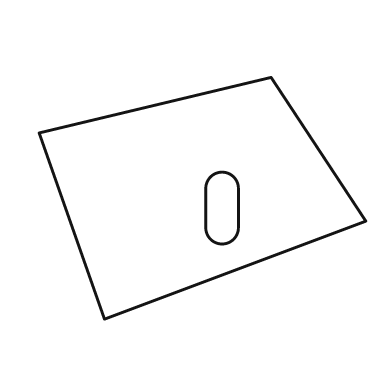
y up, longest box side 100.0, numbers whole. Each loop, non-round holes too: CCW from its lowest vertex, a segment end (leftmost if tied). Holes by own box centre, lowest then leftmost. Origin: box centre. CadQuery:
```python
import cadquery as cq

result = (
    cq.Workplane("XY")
    .moveTo(-30.0, -37.0)
    .lineTo(50.0, -7.0)
    .lineTo(21.0, 37.0)
    .lineTo(-50.0, 20.0)
    .close()
    .moveTo(1.0, -9.0)
    .threePointArc((6.0, -14.0), (11.0, -9.0))
    .lineTo(11.0, 3.0)
    .threePointArc((6.0, 8.0), (1.0, 3.0))
    .close()
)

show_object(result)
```